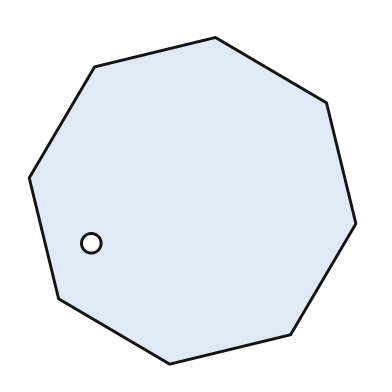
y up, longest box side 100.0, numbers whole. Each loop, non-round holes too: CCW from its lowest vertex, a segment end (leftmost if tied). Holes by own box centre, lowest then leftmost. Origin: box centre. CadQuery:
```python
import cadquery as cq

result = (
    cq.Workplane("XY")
    .moveTo(-7.0, -50.0)
    .lineTo(30.0, -41.0)
    .lineTo(50.0, -7.0)
    .lineTo(41.0, 30.0)
    .lineTo(7.0, 50.0)
    .lineTo(-30.0, 41.0)
    .lineTo(-50.0, 7.0)
    .lineTo(-41.0, -30.0)
    .close()
    .moveTo(-31.0, -13.0)
    .circle(3.0)
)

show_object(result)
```